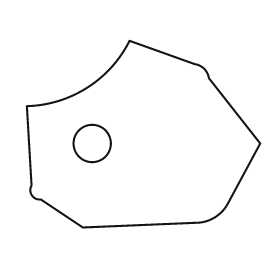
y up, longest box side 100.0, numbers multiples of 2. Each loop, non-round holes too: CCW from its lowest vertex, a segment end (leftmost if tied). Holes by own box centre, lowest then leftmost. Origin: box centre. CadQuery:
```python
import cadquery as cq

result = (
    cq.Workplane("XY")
    .moveTo(-26.0, -40.0)
    .lineTo(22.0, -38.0)
    .threePointArc((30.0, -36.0), (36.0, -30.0))
    .lineTo(50.0, -4.0)
    .lineTo(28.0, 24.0)
    .threePointArc((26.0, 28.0), (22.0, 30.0))
    .lineTo(-6.0, 40.0)
    .threePointArc((-24.0, 20.0), (-50.0, 12.0))
    .lineTo(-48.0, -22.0)
    .threePointArc((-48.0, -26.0), (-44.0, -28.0))
    .close()
    .moveTo(-22.0, -4.0)
    .circle(8.0)
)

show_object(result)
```